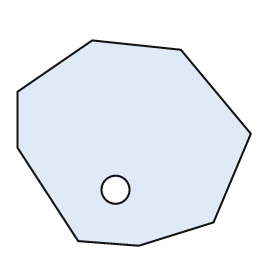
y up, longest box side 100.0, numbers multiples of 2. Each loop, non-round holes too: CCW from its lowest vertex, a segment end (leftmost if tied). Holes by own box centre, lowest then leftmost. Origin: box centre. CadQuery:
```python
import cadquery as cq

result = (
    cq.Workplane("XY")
    .moveTo(2.0, -44.0)
    .lineTo(34.0, -34.0)
    .lineTo(50.0, 4.0)
    .lineTo(20.0, 40.0)
    .lineTo(-18.0, 44.0)
    .lineTo(-50.0, 22.0)
    .lineTo(-50.0, -2.0)
    .lineTo(-24.0, -42.0)
    .close()
    .moveTo(-8.0, -20.0)
    .circle(6.0)
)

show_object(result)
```